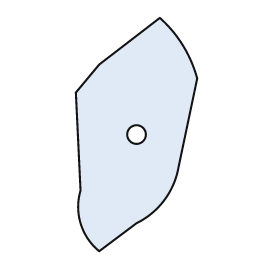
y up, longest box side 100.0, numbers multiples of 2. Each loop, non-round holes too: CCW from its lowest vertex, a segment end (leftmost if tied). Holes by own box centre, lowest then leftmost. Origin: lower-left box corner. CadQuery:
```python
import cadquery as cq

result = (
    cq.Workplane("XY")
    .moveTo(10.0, 0.0)
    .lineTo(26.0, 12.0)
    .threePointArc((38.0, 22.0), (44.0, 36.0))
    .lineTo(52.0, 74.0)
    .threePointArc((46.0, 88.0), (36.0, 100.0))
    .lineTo(10.0, 80.0)
    .lineTo(0.0, 68.0)
    .lineTo(2.0, 26.0)
    .threePointArc((2.0, 12.0), (10.0, 0.0))
    .close()
    .moveTo(26.0, 50.0)
    .circle(4.0)
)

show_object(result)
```